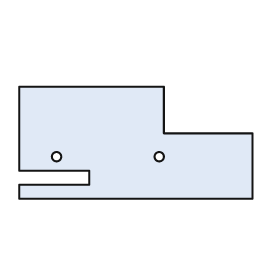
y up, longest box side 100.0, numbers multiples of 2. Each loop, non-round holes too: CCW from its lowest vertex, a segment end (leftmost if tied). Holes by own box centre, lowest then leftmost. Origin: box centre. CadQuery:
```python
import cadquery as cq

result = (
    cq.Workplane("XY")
    .moveTo(-50.0, -24.0)
    .lineTo(50.0, -24.0)
    .lineTo(50.0, 4.0)
    .lineTo(12.0, 4.0)
    .lineTo(12.0, 24.0)
    .lineTo(-50.0, 24.0)
    .lineTo(-50.0, -12.0)
    .lineTo(-20.0, -12.0)
    .lineTo(-20.0, -18.0)
    .lineTo(-50.0, -18.0)
    .close()
    .moveTo(-34.0, -6.0)
    .circle(2.0)
    .moveTo(10.0, -6.0)
    .circle(2.0)
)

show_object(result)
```